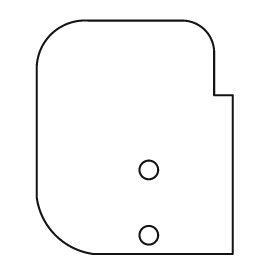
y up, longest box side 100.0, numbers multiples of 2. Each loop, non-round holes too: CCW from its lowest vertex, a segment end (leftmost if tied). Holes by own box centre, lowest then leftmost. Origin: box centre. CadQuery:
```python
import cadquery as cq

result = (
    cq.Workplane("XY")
    .moveTo(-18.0, -50.0)
    .lineTo(42.0, -50.0)
    .lineTo(42.0, 18.0)
    .lineTo(34.0, 18.0)
    .lineTo(34.0, 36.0)
    .threePointArc((30.0, 46.0), (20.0, 50.0))
    .lineTo(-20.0, 50.0)
    .threePointArc((-36.0, 44.0), (-42.0, 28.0))
    .lineTo(-42.0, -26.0)
    .threePointArc((-34.0, -42.0), (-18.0, -50.0))
    .close()
    .moveTo(6.0, -42.0)
    .circle(4.0)
    .moveTo(6.0, -14.0)
    .circle(4.0)
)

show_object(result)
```